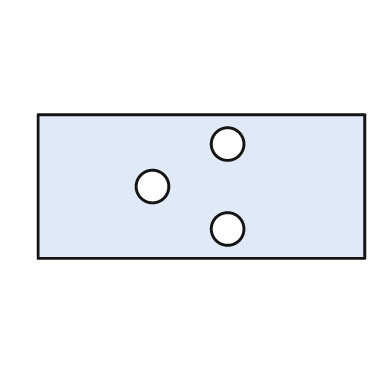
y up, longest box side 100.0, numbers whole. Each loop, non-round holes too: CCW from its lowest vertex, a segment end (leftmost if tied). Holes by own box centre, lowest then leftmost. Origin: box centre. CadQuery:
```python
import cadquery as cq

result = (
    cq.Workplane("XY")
    .moveTo(-50.0, -22.0)
    .lineTo(50.0, -22.0)
    .lineTo(50.0, 22.0)
    .lineTo(-50.0, 22.0)
    .close()
    .moveTo(8.0, -13.0)
    .circle(5.0)
    .moveTo(-15.0, 0.0)
    .circle(5.0)
    .moveTo(8.0, 13.0)
    .circle(5.0)
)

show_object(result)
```